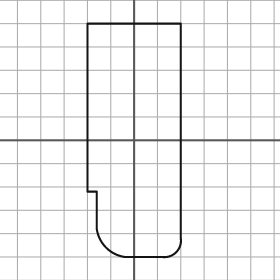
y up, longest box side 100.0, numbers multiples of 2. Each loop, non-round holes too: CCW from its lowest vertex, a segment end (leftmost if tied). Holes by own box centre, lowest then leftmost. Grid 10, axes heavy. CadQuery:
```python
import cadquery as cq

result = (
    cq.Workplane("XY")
    .moveTo(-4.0, -50.0)
    .lineTo(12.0, -50.0)
    .threePointArc((18.0, -48.0), (20.0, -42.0))
    .lineTo(20.0, 50.0)
    .lineTo(-20.0, 50.0)
    .lineTo(-20.0, -22.0)
    .lineTo(-16.0, -22.0)
    .lineTo(-16.0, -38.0)
    .threePointArc((-12.0, -46.0), (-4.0, -50.0))
    .close()
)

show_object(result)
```